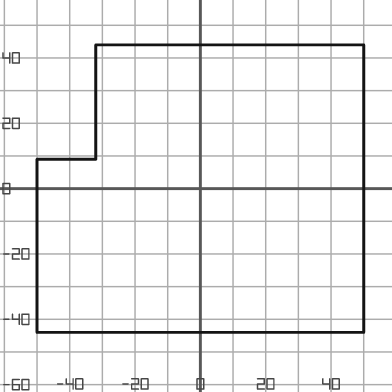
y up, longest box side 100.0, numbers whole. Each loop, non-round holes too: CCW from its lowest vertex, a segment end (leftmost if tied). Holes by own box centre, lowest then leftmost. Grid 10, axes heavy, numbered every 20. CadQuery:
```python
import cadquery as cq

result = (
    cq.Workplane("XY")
    .moveTo(-50.0, -44.0)
    .lineTo(50.0, -44.0)
    .lineTo(50.0, 44.0)
    .lineTo(-32.0, 44.0)
    .lineTo(-32.0, 9.0)
    .lineTo(-50.0, 9.0)
    .close()
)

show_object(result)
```